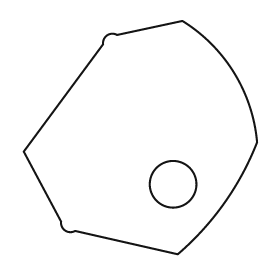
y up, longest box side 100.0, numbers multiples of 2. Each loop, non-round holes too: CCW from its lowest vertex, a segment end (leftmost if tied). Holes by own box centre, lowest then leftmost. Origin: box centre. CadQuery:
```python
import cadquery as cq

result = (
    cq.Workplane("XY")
    .moveTo(16.0, -50.0)
    .threePointArc((36.0, -28.0), (50.0, -2.0))
    .threePointArc((40.0, 28.0), (18.0, 50.0))
    .lineTo(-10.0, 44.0)
    .threePointArc((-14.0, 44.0), (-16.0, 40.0))
    .lineTo(-50.0, -6.0)
    .lineTo(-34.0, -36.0)
    .threePointArc((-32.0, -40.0), (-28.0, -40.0))
    .close()
    .moveTo(14.0, -20.0)
    .circle(10.0)
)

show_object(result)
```